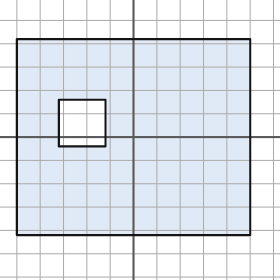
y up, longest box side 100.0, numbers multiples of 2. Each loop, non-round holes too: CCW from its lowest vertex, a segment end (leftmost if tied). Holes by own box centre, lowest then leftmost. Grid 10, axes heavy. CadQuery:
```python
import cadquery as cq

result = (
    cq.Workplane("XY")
    .moveTo(-50.0, -42.0)
    .lineTo(50.0, -42.0)
    .lineTo(50.0, 42.0)
    .lineTo(-50.0, 42.0)
    .close()
    .moveTo(-32.0, -4.0)
    .lineTo(-12.0, -4.0)
    .lineTo(-12.0, 16.0)
    .lineTo(-32.0, 16.0)
    .close()
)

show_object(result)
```